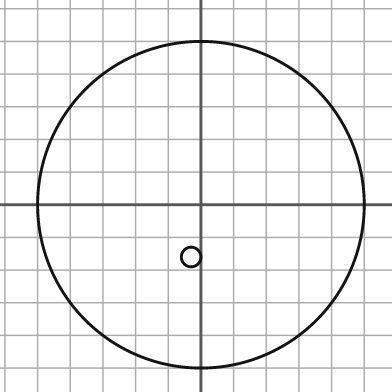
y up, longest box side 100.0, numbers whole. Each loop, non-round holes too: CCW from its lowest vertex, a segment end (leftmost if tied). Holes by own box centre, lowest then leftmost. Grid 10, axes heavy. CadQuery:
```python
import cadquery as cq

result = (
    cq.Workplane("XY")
    .moveTo(0.0, 0.0)
    .circle(50.0)
    .moveTo(-3.0, -16.0)
    .circle(3.0)
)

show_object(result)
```